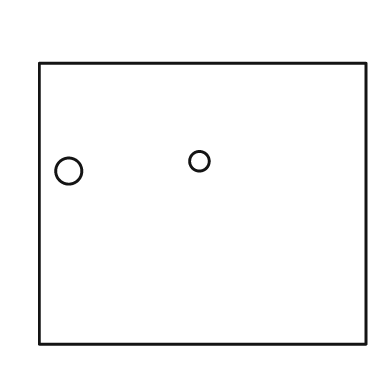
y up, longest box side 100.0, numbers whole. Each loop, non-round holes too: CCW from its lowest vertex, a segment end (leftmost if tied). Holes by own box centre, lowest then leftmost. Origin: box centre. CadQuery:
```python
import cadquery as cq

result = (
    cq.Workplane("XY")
    .moveTo(-50.0, -43.0)
    .lineTo(50.0, -43.0)
    .lineTo(50.0, 43.0)
    .lineTo(-50.0, 43.0)
    .close()
    .moveTo(-41.0, 10.0)
    .circle(4.0)
    .moveTo(-1.0, 13.0)
    .circle(3.0)
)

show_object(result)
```